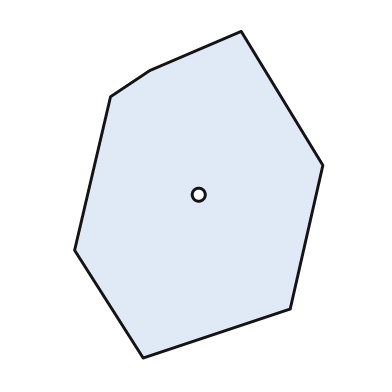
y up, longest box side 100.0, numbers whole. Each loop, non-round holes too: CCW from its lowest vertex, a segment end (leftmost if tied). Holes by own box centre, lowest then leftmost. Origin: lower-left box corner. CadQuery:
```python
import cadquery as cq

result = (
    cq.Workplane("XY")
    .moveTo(21.0, 0.0)
    .lineTo(66.0, 15.0)
    .lineTo(76.0, 59.0)
    .lineTo(51.0, 100.0)
    .lineTo(23.0, 88.0)
    .lineTo(11.0, 80.0)
    .lineTo(0.0, 33.0)
    .close()
    .moveTo(38.0, 50.0)
    .circle(2.0)
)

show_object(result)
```